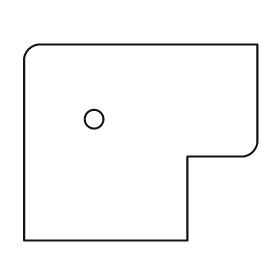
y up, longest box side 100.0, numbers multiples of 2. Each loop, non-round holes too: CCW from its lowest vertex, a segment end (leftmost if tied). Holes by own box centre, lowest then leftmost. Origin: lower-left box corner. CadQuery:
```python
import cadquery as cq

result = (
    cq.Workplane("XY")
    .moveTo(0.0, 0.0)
    .lineTo(70.0, 0.0)
    .lineTo(70.0, 36.0)
    .lineTo(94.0, 36.0)
    .threePointArc((98.0, 38.0), (100.0, 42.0))
    .lineTo(100.0, 84.0)
    .lineTo(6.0, 84.0)
    .threePointArc((2.0, 82.0), (0.0, 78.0))
    .close()
    .moveTo(30.0, 52.0)
    .circle(4.0)
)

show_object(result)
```